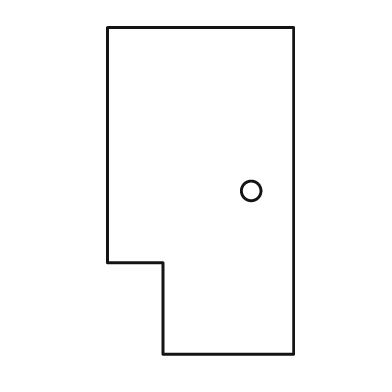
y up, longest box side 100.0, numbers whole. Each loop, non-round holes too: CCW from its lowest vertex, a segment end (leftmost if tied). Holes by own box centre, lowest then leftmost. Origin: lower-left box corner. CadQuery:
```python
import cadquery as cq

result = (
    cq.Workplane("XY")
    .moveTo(17.0, 0.0)
    .lineTo(57.0, 0.0)
    .lineTo(57.0, 100.0)
    .lineTo(0.0, 100.0)
    .lineTo(0.0, 28.0)
    .lineTo(17.0, 28.0)
    .close()
    .moveTo(44.0, 50.0)
    .circle(3.0)
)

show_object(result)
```